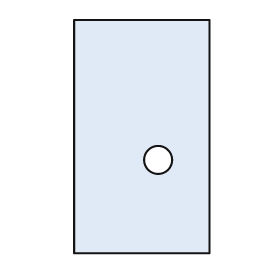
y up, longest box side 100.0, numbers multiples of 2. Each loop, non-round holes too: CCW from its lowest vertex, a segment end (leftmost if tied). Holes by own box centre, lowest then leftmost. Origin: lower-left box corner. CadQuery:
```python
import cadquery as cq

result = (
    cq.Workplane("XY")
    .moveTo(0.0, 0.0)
    .lineTo(58.0, 0.0)
    .lineTo(58.0, 100.0)
    .lineTo(0.0, 100.0)
    .close()
    .moveTo(36.0, 40.0)
    .circle(6.0)
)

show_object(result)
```